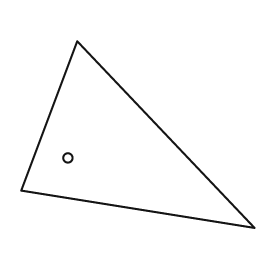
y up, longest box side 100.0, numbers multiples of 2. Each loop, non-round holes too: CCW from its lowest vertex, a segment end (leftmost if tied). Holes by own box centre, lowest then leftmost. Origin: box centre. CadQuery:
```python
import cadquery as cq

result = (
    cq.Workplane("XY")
    .moveTo(50.0, -40.0)
    .lineTo(-26.0, 40.0)
    .lineTo(-50.0, -24.0)
    .close()
    .moveTo(-30.0, -10.0)
    .circle(2.0)
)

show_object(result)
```